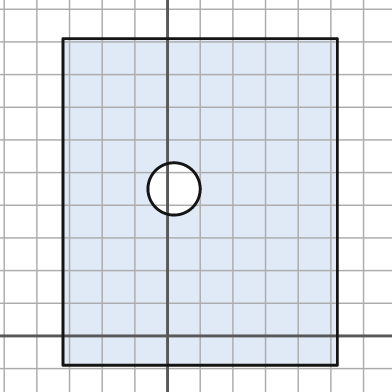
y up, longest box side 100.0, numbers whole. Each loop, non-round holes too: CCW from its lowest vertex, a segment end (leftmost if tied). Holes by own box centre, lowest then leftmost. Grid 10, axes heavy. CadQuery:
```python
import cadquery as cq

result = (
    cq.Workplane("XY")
    .moveTo(-32.0, -9.0)
    .lineTo(52.0, -9.0)
    .lineTo(52.0, 91.0)
    .lineTo(-32.0, 91.0)
    .close()
    .moveTo(2.0, 45.0)
    .circle(8.0)
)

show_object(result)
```